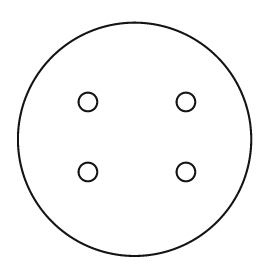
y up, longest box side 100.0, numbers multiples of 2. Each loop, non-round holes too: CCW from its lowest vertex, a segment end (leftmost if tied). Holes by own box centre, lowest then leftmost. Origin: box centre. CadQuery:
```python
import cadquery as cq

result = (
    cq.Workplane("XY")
    .moveTo(0.0, 0.0)
    .circle(50.0)
    .moveTo(-20.0, -14.0)
    .circle(4.0)
    .moveTo(22.0, -14.0)
    .circle(4.0)
    .moveTo(-20.0, 16.0)
    .circle(4.0)
    .moveTo(22.0, 16.0)
    .circle(4.0)
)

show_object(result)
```